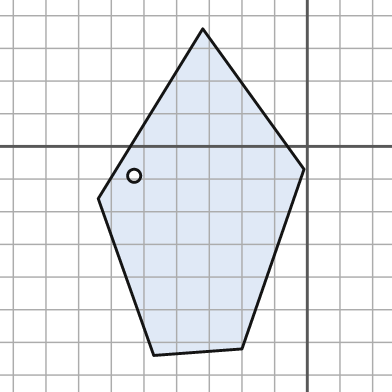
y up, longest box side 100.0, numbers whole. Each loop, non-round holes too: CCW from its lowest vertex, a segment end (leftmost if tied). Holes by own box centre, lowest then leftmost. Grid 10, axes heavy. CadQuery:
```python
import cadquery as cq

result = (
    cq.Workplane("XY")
    .moveTo(-47.0, -64.0)
    .lineTo(-20.0, -62.0)
    .lineTo(-1.0, -7.0)
    .lineTo(-32.0, 36.0)
    .lineTo(-64.0, -16.0)
    .close()
    .moveTo(-53.0, -9.0)
    .circle(2.0)
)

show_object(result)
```